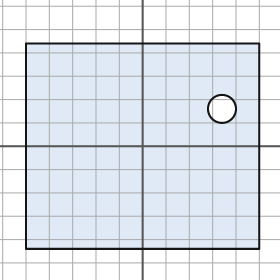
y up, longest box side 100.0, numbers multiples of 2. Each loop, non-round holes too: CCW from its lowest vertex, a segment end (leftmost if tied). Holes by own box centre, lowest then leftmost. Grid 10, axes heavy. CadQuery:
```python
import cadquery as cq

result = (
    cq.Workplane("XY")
    .moveTo(-50.0, -44.0)
    .lineTo(50.0, -44.0)
    .lineTo(50.0, 44.0)
    .lineTo(-50.0, 44.0)
    .close()
    .moveTo(34.0, 16.0)
    .circle(6.0)
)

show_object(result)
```